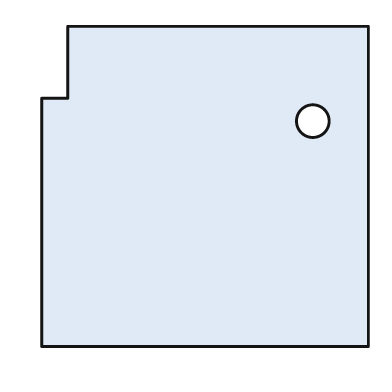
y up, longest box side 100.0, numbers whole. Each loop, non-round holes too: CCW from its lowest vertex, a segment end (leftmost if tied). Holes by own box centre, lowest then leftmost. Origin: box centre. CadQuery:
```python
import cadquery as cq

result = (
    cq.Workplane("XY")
    .moveTo(-50.0, -49.0)
    .lineTo(50.0, -49.0)
    .lineTo(50.0, 49.0)
    .lineTo(-42.0, 49.0)
    .lineTo(-42.0, 27.0)
    .lineTo(-50.0, 27.0)
    .close()
    .moveTo(33.0, 20.0)
    .circle(5.0)
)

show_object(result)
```